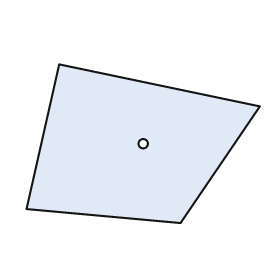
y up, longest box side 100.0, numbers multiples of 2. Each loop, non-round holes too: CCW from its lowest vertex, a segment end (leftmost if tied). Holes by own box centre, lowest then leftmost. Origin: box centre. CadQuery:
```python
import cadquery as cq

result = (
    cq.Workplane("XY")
    .moveTo(16.0, -34.0)
    .lineTo(50.0, 16.0)
    .lineTo(-36.0, 34.0)
    .lineTo(-50.0, -28.0)
    .close()
    .moveTo(0.0, 0.0)
    .circle(2.0)
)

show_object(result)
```